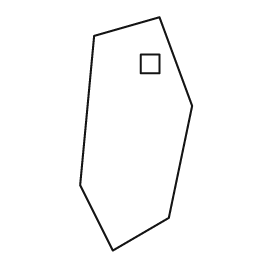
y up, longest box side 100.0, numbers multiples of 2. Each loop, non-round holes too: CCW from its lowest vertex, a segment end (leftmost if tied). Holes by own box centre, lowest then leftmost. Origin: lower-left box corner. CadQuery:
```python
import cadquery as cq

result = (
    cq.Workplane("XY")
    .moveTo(14.0, 0.0)
    .lineTo(38.0, 14.0)
    .lineTo(48.0, 62.0)
    .lineTo(34.0, 100.0)
    .lineTo(6.0, 92.0)
    .lineTo(0.0, 28.0)
    .close()
    .moveTo(26.0, 76.0)
    .lineTo(34.0, 76.0)
    .lineTo(34.0, 84.0)
    .lineTo(26.0, 84.0)
    .close()
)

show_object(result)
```